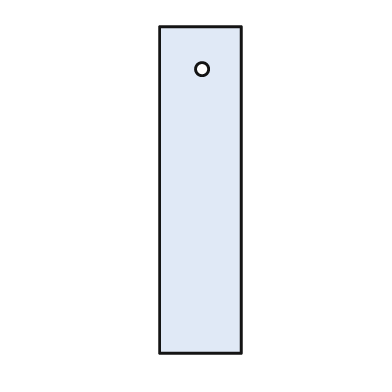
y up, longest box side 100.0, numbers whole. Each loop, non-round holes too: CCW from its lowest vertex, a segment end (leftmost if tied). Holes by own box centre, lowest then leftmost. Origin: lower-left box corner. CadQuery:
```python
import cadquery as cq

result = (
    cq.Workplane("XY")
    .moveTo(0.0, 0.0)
    .lineTo(25.0, 0.0)
    .lineTo(25.0, 100.0)
    .lineTo(0.0, 100.0)
    .close()
    .moveTo(13.0, 87.0)
    .circle(2.0)
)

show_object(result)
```